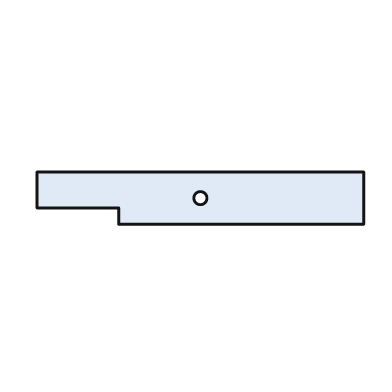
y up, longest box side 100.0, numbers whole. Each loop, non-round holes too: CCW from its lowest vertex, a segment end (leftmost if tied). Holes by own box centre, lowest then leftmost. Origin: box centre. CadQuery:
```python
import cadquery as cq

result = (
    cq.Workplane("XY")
    .moveTo(-25.0, -8.0)
    .lineTo(50.0, -8.0)
    .lineTo(50.0, 8.0)
    .lineTo(-50.0, 8.0)
    .lineTo(-50.0, -3.0)
    .lineTo(-25.0, -3.0)
    .close()
    .moveTo(0.0, 0.0)
    .circle(2.0)
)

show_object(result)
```